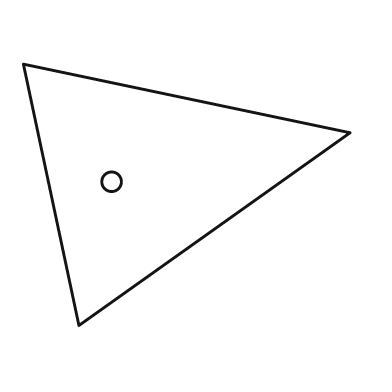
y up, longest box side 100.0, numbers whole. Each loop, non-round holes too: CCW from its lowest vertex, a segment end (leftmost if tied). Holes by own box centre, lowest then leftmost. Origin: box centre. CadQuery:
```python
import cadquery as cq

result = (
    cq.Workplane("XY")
    .moveTo(-33.0, -40.0)
    .lineTo(50.0, 19.0)
    .lineTo(-50.0, 40.0)
    .close()
    .moveTo(-23.0, 4.0)
    .circle(3.0)
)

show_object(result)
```